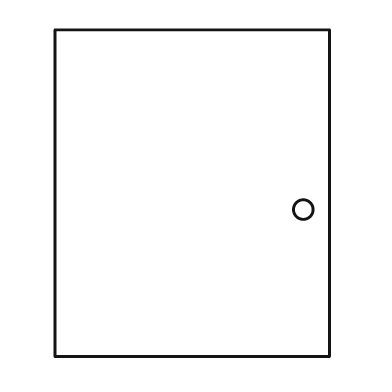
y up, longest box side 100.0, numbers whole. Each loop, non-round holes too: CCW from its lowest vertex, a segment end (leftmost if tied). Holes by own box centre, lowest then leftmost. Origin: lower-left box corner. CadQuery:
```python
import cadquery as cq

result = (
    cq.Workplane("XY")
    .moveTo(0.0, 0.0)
    .lineTo(84.0, 0.0)
    .lineTo(84.0, 100.0)
    .lineTo(0.0, 100.0)
    .close()
    .moveTo(76.0, 45.0)
    .circle(3.0)
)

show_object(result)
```